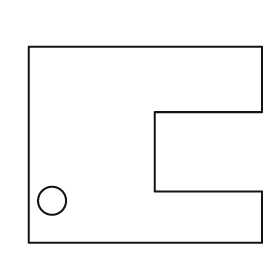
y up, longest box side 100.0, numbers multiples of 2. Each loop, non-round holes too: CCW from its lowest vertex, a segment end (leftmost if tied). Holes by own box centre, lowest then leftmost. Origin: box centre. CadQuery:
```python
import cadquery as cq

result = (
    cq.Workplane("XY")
    .moveTo(-50.0, -42.0)
    .lineTo(50.0, -42.0)
    .lineTo(50.0, -20.0)
    .lineTo(4.0, -20.0)
    .lineTo(4.0, 14.0)
    .lineTo(50.0, 14.0)
    .lineTo(50.0, 42.0)
    .lineTo(-50.0, 42.0)
    .close()
    .moveTo(-40.0, -24.0)
    .circle(6.0)
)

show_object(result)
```